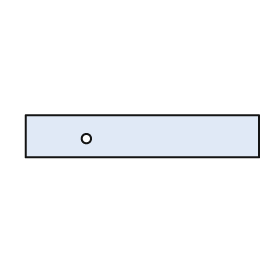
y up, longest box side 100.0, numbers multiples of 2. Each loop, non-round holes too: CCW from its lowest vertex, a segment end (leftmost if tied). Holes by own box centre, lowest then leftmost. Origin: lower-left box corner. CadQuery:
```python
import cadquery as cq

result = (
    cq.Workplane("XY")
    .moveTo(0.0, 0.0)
    .lineTo(100.0, 0.0)
    .lineTo(100.0, 18.0)
    .lineTo(0.0, 18.0)
    .close()
    .moveTo(26.0, 8.0)
    .circle(2.0)
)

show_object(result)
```